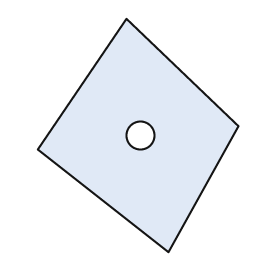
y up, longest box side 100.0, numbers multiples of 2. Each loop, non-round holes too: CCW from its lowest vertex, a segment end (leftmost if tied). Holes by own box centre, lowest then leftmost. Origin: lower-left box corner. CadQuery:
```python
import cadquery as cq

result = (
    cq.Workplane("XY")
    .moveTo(56.0, 0.0)
    .lineTo(86.0, 54.0)
    .lineTo(38.0, 100.0)
    .lineTo(0.0, 44.0)
    .close()
    .moveTo(44.0, 50.0)
    .circle(6.0)
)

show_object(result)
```